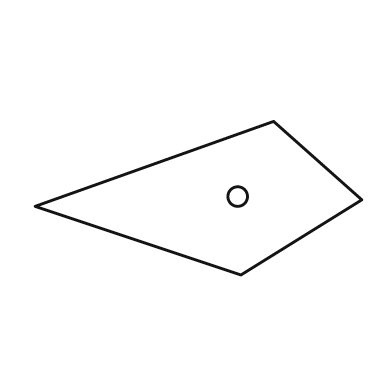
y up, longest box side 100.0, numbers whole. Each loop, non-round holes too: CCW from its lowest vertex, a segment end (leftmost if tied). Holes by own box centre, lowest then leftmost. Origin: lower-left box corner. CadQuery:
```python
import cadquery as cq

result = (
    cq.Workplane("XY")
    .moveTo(63.0, 0.0)
    .lineTo(100.0, 23.0)
    .lineTo(73.0, 47.0)
    .lineTo(0.0, 21.0)
    .close()
    .moveTo(62.0, 24.0)
    .circle(3.0)
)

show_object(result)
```